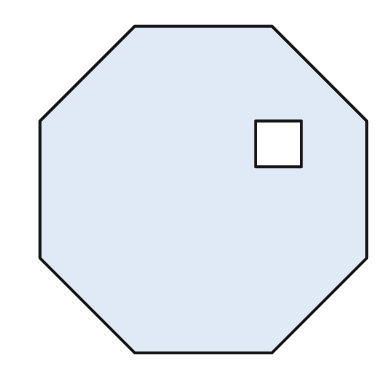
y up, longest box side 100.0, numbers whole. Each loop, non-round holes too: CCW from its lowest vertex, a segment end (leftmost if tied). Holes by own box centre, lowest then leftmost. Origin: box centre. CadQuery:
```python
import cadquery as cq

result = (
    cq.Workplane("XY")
    .moveTo(-21.0, -50.0)
    .lineTo(21.0, -50.0)
    .lineTo(50.0, -21.0)
    .lineTo(50.0, 21.0)
    .lineTo(21.0, 50.0)
    .lineTo(-21.0, 50.0)
    .lineTo(-50.0, 21.0)
    .lineTo(-50.0, -21.0)
    .close()
    .moveTo(16.0, 7.0)
    .lineTo(30.0, 7.0)
    .lineTo(30.0, 21.0)
    .lineTo(16.0, 21.0)
    .close()
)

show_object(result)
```